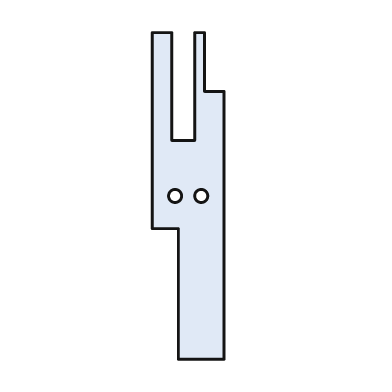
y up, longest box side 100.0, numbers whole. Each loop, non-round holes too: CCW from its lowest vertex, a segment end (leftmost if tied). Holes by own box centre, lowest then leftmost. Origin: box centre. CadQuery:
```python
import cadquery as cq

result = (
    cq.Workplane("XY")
    .moveTo(-3.0, -50.0)
    .lineTo(11.0, -50.0)
    .lineTo(11.0, 32.0)
    .lineTo(5.0, 32.0)
    .lineTo(5.0, 50.0)
    .lineTo(2.0, 50.0)
    .lineTo(2.0, 17.0)
    .lineTo(-5.0, 17.0)
    .lineTo(-5.0, 50.0)
    .lineTo(-11.0, 50.0)
    .lineTo(-11.0, -10.0)
    .lineTo(-3.0, -10.0)
    .close()
    .moveTo(-4.0, 0.0)
    .circle(2.0)
    .moveTo(4.0, 0.0)
    .circle(2.0)
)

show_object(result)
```